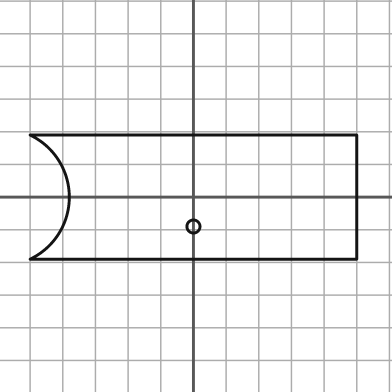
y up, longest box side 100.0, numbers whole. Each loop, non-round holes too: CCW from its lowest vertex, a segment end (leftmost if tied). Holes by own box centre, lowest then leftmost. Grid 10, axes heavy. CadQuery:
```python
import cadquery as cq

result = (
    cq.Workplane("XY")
    .moveTo(-50.0, -19.0)
    .lineTo(50.0, -19.0)
    .lineTo(50.0, 19.0)
    .lineTo(-50.0, 19.0)
    .threePointArc((-38.0, 0.0), (-50.0, -19.0))
    .close()
    .moveTo(0.0, -9.0)
    .circle(2.0)
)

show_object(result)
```